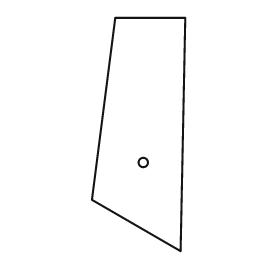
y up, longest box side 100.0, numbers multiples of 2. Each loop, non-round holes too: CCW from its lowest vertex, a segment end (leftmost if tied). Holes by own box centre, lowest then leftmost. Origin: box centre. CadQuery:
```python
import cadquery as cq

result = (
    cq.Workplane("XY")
    .moveTo(18.0, -50.0)
    .lineTo(20.0, 50.0)
    .lineTo(-10.0, 50.0)
    .lineTo(-20.0, -28.0)
    .close()
    .moveTo(2.0, -12.0)
    .circle(2.0)
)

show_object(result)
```